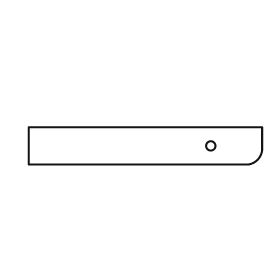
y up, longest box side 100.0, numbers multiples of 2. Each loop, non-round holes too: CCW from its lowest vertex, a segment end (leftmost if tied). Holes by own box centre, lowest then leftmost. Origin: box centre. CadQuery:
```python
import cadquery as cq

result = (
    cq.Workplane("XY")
    .moveTo(-50.0, -8.0)
    .lineTo(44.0, -8.0)
    .threePointArc((48.0, -6.0), (50.0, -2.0))
    .lineTo(50.0, 8.0)
    .lineTo(-50.0, 8.0)
    .close()
    .moveTo(28.0, 0.0)
    .circle(2.0)
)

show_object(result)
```